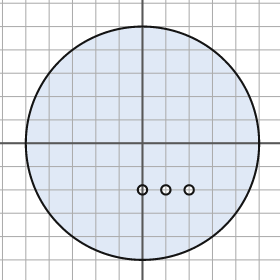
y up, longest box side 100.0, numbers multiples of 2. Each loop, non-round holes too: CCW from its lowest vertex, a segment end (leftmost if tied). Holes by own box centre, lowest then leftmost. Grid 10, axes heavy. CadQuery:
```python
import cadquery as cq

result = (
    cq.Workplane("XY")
    .moveTo(0.0, 0.0)
    .circle(50.0)
    .moveTo(0.0, -20.0)
    .circle(2.0)
    .moveTo(10.0, -20.0)
    .circle(2.0)
    .moveTo(20.0, -20.0)
    .circle(2.0)
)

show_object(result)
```